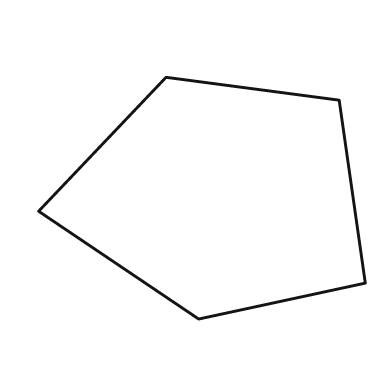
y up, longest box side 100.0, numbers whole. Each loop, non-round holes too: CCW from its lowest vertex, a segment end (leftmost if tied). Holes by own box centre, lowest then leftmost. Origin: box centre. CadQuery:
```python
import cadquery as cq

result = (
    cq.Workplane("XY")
    .moveTo(-1.0, -37.0)
    .lineTo(50.0, -26.0)
    .lineTo(42.0, 30.0)
    .lineTo(-11.0, 37.0)
    .lineTo(-50.0, -4.0)
    .close()
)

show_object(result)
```